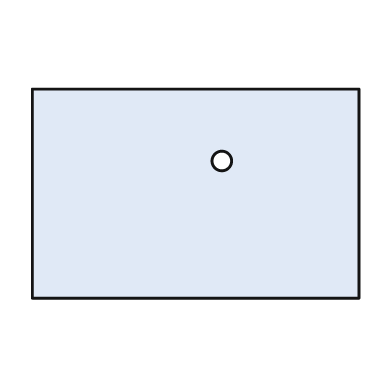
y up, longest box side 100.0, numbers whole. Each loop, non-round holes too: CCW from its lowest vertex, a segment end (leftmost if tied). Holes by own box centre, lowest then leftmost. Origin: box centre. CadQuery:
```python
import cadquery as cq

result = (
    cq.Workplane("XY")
    .moveTo(-50.0, -32.0)
    .lineTo(50.0, -32.0)
    .lineTo(50.0, 32.0)
    .lineTo(-50.0, 32.0)
    .close()
    .moveTo(8.0, 10.0)
    .circle(3.0)
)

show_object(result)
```